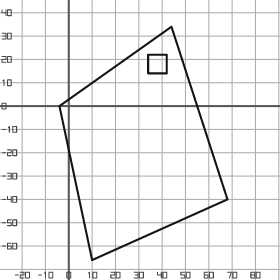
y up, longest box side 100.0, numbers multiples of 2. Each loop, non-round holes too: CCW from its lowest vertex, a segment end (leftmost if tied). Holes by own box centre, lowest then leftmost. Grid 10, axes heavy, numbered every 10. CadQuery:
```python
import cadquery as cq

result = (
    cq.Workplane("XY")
    .moveTo(10.0, -66.0)
    .lineTo(68.0, -40.0)
    .lineTo(44.0, 34.0)
    .lineTo(-4.0, 0.0)
    .close()
    .moveTo(34.0, 14.0)
    .lineTo(42.0, 14.0)
    .lineTo(42.0, 22.0)
    .lineTo(34.0, 22.0)
    .close()
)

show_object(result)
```